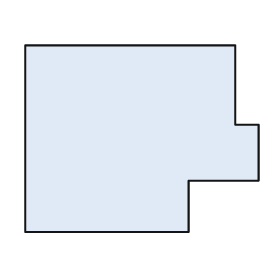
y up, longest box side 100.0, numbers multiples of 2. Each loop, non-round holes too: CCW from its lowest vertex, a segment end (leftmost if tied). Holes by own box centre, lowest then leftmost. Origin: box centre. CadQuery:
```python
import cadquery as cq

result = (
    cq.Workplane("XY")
    .moveTo(-50.0, -40.0)
    .lineTo(20.0, -40.0)
    .lineTo(20.0, -18.0)
    .lineTo(50.0, -18.0)
    .lineTo(50.0, 6.0)
    .lineTo(40.0, 6.0)
    .lineTo(40.0, 40.0)
    .lineTo(-50.0, 40.0)
    .close()
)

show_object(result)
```